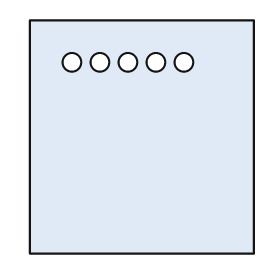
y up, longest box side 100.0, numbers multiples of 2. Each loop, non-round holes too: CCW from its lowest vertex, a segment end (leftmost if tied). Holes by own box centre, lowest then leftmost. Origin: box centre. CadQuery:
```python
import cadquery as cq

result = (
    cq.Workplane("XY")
    .moveTo(-48.0, -50.0)
    .lineTo(48.0, -50.0)
    .lineTo(48.0, 50.0)
    .lineTo(-48.0, 50.0)
    .close()
    .moveTo(-30.0, 32.0)
    .circle(4.0)
    .moveTo(-18.0, 32.0)
    .circle(4.0)
    .moveTo(-6.0, 32.0)
    .circle(4.0)
    .moveTo(6.0, 32.0)
    .circle(4.0)
    .moveTo(18.0, 32.0)
    .circle(4.0)
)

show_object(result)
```